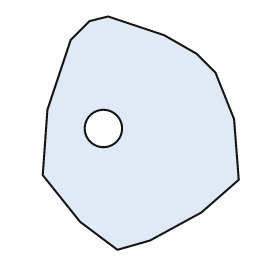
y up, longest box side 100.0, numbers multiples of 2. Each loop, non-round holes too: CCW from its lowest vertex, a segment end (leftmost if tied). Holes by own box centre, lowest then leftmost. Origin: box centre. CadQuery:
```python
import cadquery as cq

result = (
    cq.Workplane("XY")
    .moveTo(-10.0, -50.0)
    .lineTo(4.0, -46.0)
    .lineTo(26.0, -34.0)
    .lineTo(42.0, -20.0)
    .lineTo(40.0, 6.0)
    .lineTo(32.0, 26.0)
    .lineTo(24.0, 34.0)
    .lineTo(10.0, 42.0)
    .lineTo(-14.0, 50.0)
    .lineTo(-22.0, 48.0)
    .lineTo(-30.0, 40.0)
    .lineTo(-40.0, 10.0)
    .lineTo(-42.0, -18.0)
    .lineTo(-26.0, -38.0)
    .close()
    .moveTo(-16.0, 2.0)
    .circle(8.0)
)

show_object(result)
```